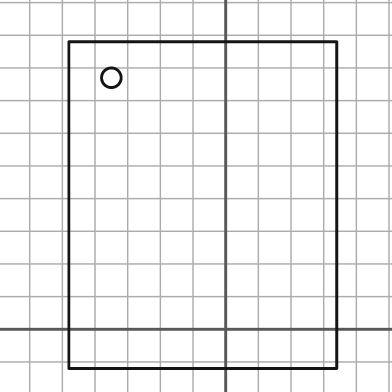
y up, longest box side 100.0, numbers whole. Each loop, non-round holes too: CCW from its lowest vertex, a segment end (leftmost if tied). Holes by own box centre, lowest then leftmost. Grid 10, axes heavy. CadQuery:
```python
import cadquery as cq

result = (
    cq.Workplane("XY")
    .moveTo(-48.0, -12.0)
    .lineTo(34.0, -12.0)
    .lineTo(34.0, 88.0)
    .lineTo(-48.0, 88.0)
    .close()
    .moveTo(-35.0, 77.0)
    .circle(3.0)
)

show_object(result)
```